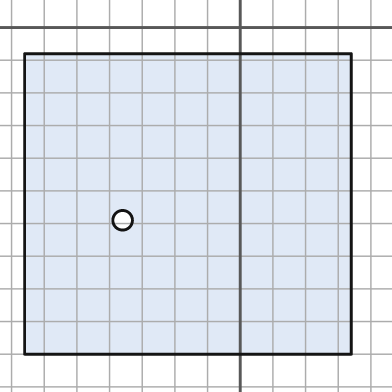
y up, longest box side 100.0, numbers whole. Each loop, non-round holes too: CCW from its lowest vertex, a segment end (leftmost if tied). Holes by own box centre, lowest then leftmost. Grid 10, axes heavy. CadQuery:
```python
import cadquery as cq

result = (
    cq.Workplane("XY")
    .moveTo(-66.0, -100.0)
    .lineTo(34.0, -100.0)
    .lineTo(34.0, -8.0)
    .lineTo(-66.0, -8.0)
    .close()
    .moveTo(-36.0, -59.0)
    .circle(3.0)
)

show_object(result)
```